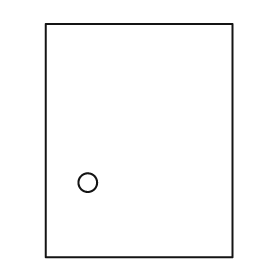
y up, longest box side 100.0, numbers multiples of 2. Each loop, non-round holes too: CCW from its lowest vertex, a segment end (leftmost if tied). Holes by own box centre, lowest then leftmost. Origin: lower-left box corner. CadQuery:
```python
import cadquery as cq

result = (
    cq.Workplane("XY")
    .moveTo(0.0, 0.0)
    .lineTo(80.0, 0.0)
    .lineTo(80.0, 100.0)
    .lineTo(0.0, 100.0)
    .close()
    .moveTo(18.0, 32.0)
    .circle(4.0)
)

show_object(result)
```